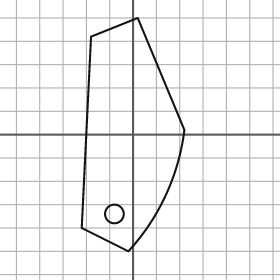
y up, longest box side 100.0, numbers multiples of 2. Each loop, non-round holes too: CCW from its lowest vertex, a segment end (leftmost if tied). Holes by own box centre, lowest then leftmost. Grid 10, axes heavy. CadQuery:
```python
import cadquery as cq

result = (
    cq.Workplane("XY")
    .moveTo(-2.0, -50.0)
    .threePointArc((14.0, -26.0), (22.0, 2.0))
    .lineTo(2.0, 50.0)
    .lineTo(-18.0, 42.0)
    .lineTo(-22.0, -40.0)
    .close()
    .moveTo(-8.0, -34.0)
    .circle(4.0)
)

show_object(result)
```